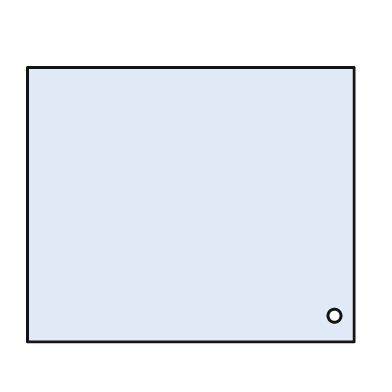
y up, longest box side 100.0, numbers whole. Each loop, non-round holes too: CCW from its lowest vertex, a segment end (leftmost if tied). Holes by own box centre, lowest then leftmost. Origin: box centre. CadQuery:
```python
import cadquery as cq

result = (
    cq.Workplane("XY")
    .moveTo(-50.0, -42.0)
    .lineTo(50.0, -42.0)
    .lineTo(50.0, 42.0)
    .lineTo(-50.0, 42.0)
    .close()
    .moveTo(44.0, -34.0)
    .circle(2.0)
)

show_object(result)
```